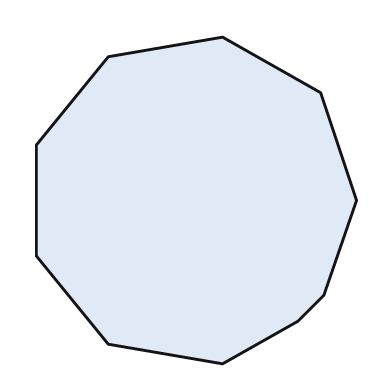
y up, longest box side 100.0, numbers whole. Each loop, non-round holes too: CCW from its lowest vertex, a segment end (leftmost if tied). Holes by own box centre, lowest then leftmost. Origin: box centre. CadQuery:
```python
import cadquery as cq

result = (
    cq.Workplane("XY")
    .moveTo(8.0, -50.0)
    .lineTo(31.0, -37.0)
    .lineTo(39.0, -29.0)
    .lineTo(49.0, 0.0)
    .lineTo(38.0, 33.0)
    .lineTo(8.0, 50.0)
    .lineTo(-27.0, 44.0)
    .lineTo(-49.0, 17.0)
    .lineTo(-49.0, -17.0)
    .lineTo(-27.0, -44.0)
    .close()
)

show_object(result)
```